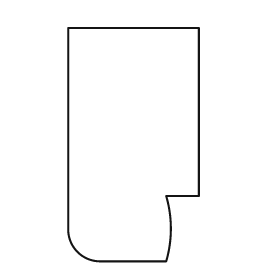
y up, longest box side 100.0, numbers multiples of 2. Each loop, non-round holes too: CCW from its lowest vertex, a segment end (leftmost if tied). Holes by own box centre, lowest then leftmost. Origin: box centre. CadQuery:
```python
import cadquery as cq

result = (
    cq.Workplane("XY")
    .moveTo(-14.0, -50.0)
    .lineTo(14.0, -50.0)
    .threePointArc((16.0, -36.0), (14.0, -22.0))
    .lineTo(28.0, -22.0)
    .lineTo(28.0, 50.0)
    .lineTo(-28.0, 50.0)
    .lineTo(-28.0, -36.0)
    .threePointArc((-24.0, -46.0), (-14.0, -50.0))
    .close()
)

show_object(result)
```